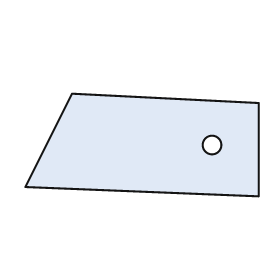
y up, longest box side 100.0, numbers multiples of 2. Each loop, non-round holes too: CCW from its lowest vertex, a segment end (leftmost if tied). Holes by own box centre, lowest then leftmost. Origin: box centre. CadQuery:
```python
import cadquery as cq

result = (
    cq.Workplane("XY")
    .moveTo(50.0, -22.0)
    .lineTo(50.0, 18.0)
    .lineTo(-30.0, 22.0)
    .lineTo(-50.0, -18.0)
    .close()
    .moveTo(30.0, 0.0)
    .circle(4.0)
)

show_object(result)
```